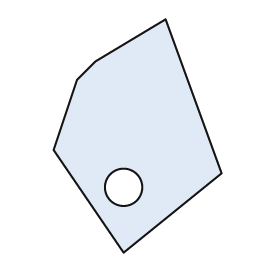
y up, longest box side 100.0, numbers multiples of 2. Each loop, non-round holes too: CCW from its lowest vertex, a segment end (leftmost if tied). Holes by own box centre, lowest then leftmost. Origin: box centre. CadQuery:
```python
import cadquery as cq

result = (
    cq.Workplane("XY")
    .moveTo(-6.0, -50.0)
    .lineTo(36.0, -16.0)
    .lineTo(12.0, 50.0)
    .lineTo(-18.0, 32.0)
    .lineTo(-26.0, 24.0)
    .lineTo(-36.0, -6.0)
    .close()
    .moveTo(-6.0, -22.0)
    .circle(8.0)
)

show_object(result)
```